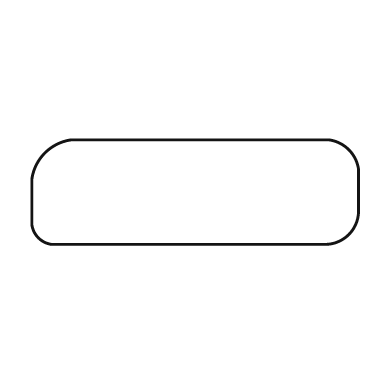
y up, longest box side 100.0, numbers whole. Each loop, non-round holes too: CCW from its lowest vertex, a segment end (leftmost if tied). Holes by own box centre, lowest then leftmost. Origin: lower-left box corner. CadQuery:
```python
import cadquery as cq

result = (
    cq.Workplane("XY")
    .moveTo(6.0, 0.0)
    .lineTo(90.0, 0.0)
    .threePointArc((97.0, 3.0), (100.0, 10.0))
    .lineTo(100.0, 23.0)
    .threePointArc((97.0, 29.0), (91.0, 32.0))
    .lineTo(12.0, 32.0)
    .threePointArc((4.0, 28.0), (0.0, 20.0))
    .lineTo(0.0, 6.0)
    .threePointArc((2.0, 2.0), (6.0, 0.0))
    .close()
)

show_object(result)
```